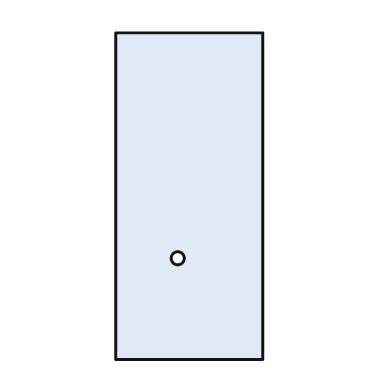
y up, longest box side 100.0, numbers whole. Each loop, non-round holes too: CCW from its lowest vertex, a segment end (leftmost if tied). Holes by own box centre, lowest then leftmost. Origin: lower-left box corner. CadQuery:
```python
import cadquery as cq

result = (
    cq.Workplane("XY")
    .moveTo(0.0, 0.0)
    .lineTo(45.0, 0.0)
    .lineTo(45.0, 100.0)
    .lineTo(0.0, 100.0)
    .close()
    .moveTo(19.0, 31.0)
    .circle(2.0)
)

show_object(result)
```